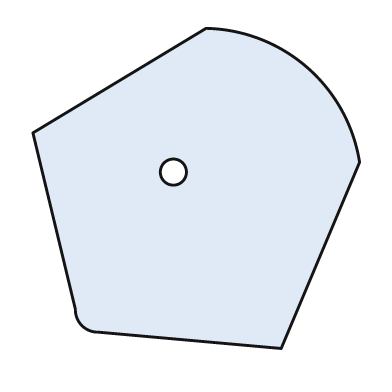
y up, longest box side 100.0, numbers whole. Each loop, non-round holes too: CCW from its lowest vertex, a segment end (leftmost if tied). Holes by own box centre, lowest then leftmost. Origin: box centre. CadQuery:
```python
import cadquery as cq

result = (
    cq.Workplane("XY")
    .moveTo(26.0, -49.0)
    .lineTo(50.0, 8.0)
    .threePointArc((34.0, 37.0), (3.0, 49.0))
    .lineTo(-50.0, 17.0)
    .lineTo(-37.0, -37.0)
    .threePointArc((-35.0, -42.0), (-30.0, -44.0))
    .close()
    .moveTo(-7.0, 5.0)
    .circle(4.0)
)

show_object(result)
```